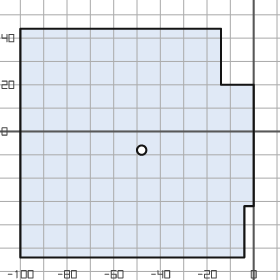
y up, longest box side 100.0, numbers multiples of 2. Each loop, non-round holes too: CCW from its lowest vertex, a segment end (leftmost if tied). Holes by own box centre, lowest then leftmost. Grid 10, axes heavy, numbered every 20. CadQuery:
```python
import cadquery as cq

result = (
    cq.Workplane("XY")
    .moveTo(-100.0, -54.0)
    .lineTo(-4.0, -54.0)
    .lineTo(-4.0, -32.0)
    .lineTo(0.0, -32.0)
    .lineTo(0.0, 20.0)
    .lineTo(-14.0, 20.0)
    .lineTo(-14.0, 44.0)
    .lineTo(-100.0, 44.0)
    .close()
    .moveTo(-48.0, -8.0)
    .circle(2.0)
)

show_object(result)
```